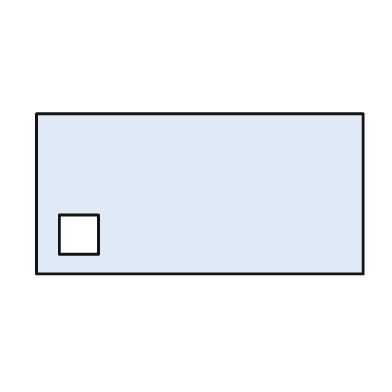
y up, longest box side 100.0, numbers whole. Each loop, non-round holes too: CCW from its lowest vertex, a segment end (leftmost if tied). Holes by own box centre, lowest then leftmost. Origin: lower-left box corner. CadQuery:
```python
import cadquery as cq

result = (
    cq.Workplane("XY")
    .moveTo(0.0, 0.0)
    .lineTo(100.0, 0.0)
    .lineTo(100.0, 49.0)
    .lineTo(0.0, 49.0)
    .close()
    .moveTo(7.0, 6.0)
    .lineTo(19.0, 6.0)
    .lineTo(19.0, 18.0)
    .lineTo(7.0, 18.0)
    .close()
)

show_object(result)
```